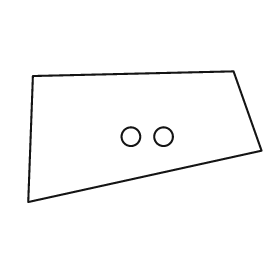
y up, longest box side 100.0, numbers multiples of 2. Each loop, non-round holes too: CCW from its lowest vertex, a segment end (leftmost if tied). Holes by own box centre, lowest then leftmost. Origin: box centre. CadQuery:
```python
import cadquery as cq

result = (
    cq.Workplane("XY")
    .moveTo(-50.0, -28.0)
    .lineTo(50.0, -6.0)
    .lineTo(38.0, 28.0)
    .lineTo(-48.0, 26.0)
    .close()
    .moveTo(-6.0, 0.0)
    .circle(4.0)
    .moveTo(8.0, 0.0)
    .circle(4.0)
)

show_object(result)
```